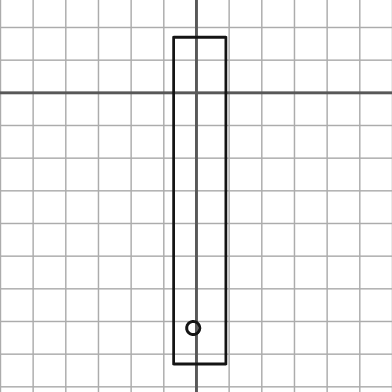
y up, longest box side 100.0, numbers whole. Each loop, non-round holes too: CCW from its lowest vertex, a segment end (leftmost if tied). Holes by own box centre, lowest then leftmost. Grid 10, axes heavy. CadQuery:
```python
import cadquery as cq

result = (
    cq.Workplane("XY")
    .moveTo(-7.0, -83.0)
    .lineTo(9.0, -83.0)
    .lineTo(9.0, 17.0)
    .lineTo(-7.0, 17.0)
    .close()
    .moveTo(-1.0, -72.0)
    .circle(2.0)
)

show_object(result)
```